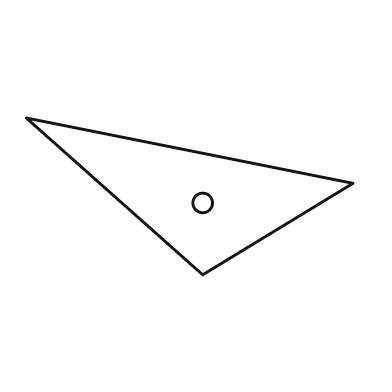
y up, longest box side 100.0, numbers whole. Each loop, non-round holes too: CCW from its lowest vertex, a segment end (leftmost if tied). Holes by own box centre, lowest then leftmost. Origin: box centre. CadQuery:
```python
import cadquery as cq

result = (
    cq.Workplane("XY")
    .moveTo(4.0, -24.0)
    .lineTo(50.0, 4.0)
    .lineTo(-50.0, 24.0)
    .close()
    .moveTo(4.0, -2.0)
    .circle(3.0)
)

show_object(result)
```